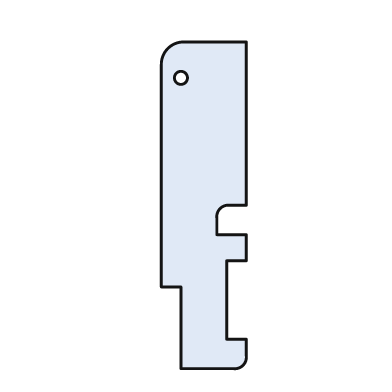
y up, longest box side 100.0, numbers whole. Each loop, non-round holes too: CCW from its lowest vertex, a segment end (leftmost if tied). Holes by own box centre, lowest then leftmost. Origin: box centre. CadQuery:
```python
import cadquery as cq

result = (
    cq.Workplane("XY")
    .moveTo(-7.0, -50.0)
    .lineTo(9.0, -50.0)
    .threePointArc((12.0, -49.0), (13.0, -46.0))
    .lineTo(13.0, -41.0)
    .lineTo(7.0, -41.0)
    .lineTo(7.0, -17.0)
    .lineTo(13.0, -17.0)
    .lineTo(13.0, -9.0)
    .lineTo(4.0, -9.0)
    .lineTo(4.0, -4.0)
    .threePointArc((5.0, -1.0), (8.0, 0.0))
    .lineTo(13.0, 0.0)
    .lineTo(13.0, 50.0)
    .lineTo(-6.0, 50.0)
    .threePointArc((-11.0, 48.0), (-13.0, 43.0))
    .lineTo(-13.0, -25.0)
    .lineTo(-7.0, -25.0)
    .close()
    .moveTo(-7.0, 39.0)
    .circle(2.0)
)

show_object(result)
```